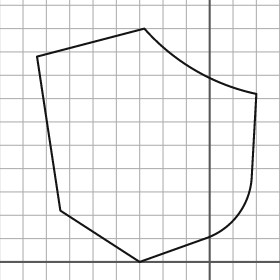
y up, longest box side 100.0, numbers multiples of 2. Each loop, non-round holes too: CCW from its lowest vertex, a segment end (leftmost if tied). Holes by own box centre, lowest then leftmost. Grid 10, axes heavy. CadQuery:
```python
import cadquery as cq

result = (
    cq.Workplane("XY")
    .moveTo(-30.0, 0.0)
    .lineTo(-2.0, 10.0)
    .threePointArc((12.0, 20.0), (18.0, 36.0))
    .lineTo(20.0, 72.0)
    .threePointArc((-6.0, 82.0), (-28.0, 100.0))
    .lineTo(-74.0, 88.0)
    .lineTo(-64.0, 22.0)
    .close()
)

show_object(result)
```